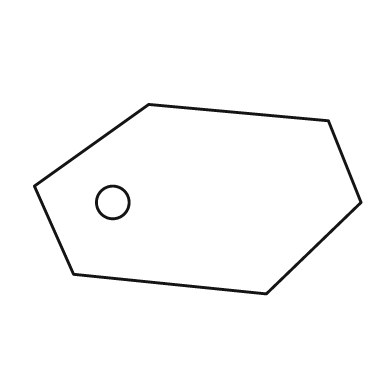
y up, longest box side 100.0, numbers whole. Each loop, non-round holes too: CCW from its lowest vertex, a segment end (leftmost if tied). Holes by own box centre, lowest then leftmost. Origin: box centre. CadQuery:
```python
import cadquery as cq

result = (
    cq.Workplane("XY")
    .moveTo(21.0, -29.0)
    .lineTo(50.0, -1.0)
    .lineTo(40.0, 24.0)
    .lineTo(-15.0, 29.0)
    .lineTo(-50.0, 4.0)
    .lineTo(-38.0, -23.0)
    .close()
    .moveTo(-26.0, -1.0)
    .circle(5.0)
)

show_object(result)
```